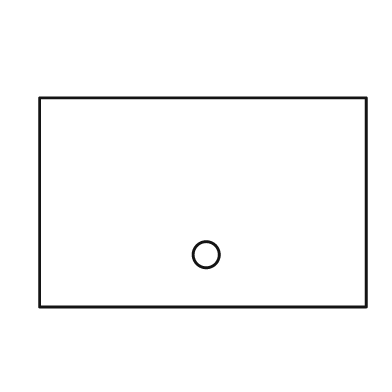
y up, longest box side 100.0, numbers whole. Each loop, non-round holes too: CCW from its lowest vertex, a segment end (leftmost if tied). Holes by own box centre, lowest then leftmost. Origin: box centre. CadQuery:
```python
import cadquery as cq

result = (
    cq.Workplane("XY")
    .moveTo(-50.0, -32.0)
    .lineTo(50.0, -32.0)
    .lineTo(50.0, 32.0)
    .lineTo(-50.0, 32.0)
    .close()
    .moveTo(1.0, -16.0)
    .circle(4.0)
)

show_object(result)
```